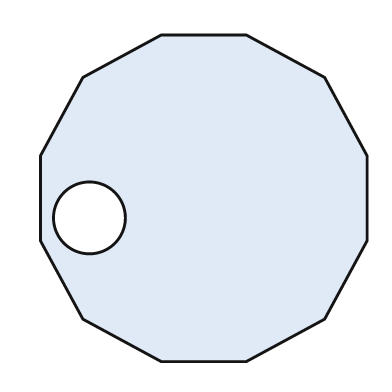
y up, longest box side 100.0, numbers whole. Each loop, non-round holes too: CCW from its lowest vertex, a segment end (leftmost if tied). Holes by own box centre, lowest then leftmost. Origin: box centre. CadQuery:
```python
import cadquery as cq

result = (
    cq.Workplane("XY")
    .moveTo(-13.0, -50.0)
    .lineTo(13.0, -50.0)
    .lineTo(37.0, -37.0)
    .lineTo(50.0, -13.0)
    .lineTo(50.0, 13.0)
    .lineTo(37.0, 37.0)
    .lineTo(13.0, 50.0)
    .lineTo(-13.0, 50.0)
    .lineTo(-37.0, 37.0)
    .lineTo(-50.0, 13.0)
    .lineTo(-50.0, -13.0)
    .lineTo(-37.0, -37.0)
    .close()
    .moveTo(-35.0, -6.0)
    .circle(11.0)
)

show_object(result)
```